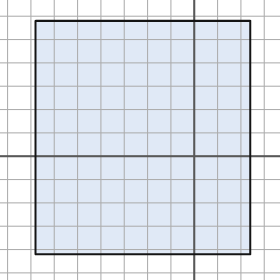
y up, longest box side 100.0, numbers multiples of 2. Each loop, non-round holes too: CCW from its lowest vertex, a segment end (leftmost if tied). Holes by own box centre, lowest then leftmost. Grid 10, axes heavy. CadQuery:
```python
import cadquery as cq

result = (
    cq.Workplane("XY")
    .moveTo(-68.0, -42.0)
    .lineTo(24.0, -42.0)
    .lineTo(24.0, 58.0)
    .lineTo(-68.0, 58.0)
    .close()
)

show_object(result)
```